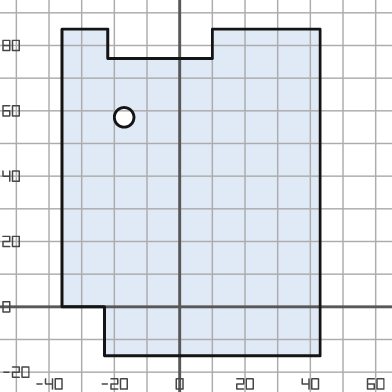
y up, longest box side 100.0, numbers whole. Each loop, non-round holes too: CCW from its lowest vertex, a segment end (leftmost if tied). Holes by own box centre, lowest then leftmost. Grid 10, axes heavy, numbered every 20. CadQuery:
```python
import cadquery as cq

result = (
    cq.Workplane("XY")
    .moveTo(-23.0, -15.0)
    .lineTo(43.0, -15.0)
    .lineTo(43.0, 85.0)
    .lineTo(10.0, 85.0)
    .lineTo(10.0, 76.0)
    .lineTo(-22.0, 76.0)
    .lineTo(-22.0, 85.0)
    .lineTo(-36.0, 85.0)
    .lineTo(-36.0, 0.0)
    .lineTo(-23.0, 0.0)
    .close()
    .moveTo(-17.0, 58.0)
    .circle(3.0)
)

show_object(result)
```